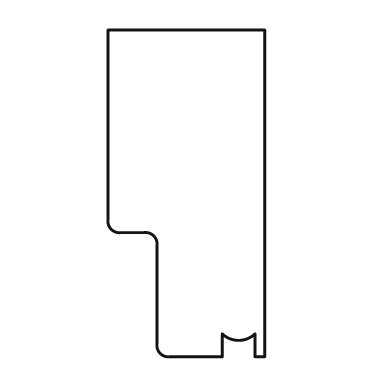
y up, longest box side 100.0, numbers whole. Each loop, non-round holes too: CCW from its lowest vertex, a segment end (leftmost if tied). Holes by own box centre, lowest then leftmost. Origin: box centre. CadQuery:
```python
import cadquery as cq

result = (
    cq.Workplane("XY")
    .moveTo(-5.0, -50.0)
    .lineTo(11.0, -50.0)
    .lineTo(11.0, -43.0)
    .threePointArc((16.0, -45.0), (21.0, -43.0))
    .lineTo(21.0, -50.0)
    .lineTo(24.0, -50.0)
    .lineTo(24.0, 50.0)
    .lineTo(-24.0, 50.0)
    .lineTo(-24.0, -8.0)
    .threePointArc((-23.0, -11.0), (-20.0, -12.0))
    .lineTo(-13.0, -12.0)
    .threePointArc((-10.0, -13.0), (-9.0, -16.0))
    .lineTo(-9.0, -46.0)
    .threePointArc((-8.0, -49.0), (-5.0, -50.0))
    .close()
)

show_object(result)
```